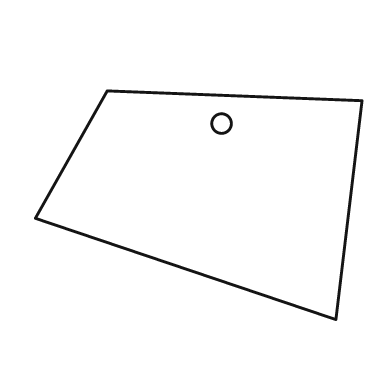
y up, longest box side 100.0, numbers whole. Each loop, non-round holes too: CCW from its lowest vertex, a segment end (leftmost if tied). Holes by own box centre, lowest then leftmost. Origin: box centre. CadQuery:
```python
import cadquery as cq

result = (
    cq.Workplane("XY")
    .moveTo(42.0, -35.0)
    .lineTo(50.0, 32.0)
    .lineTo(-28.0, 35.0)
    .lineTo(-50.0, -4.0)
    .close()
    .moveTo(7.0, 25.0)
    .circle(3.0)
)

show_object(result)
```